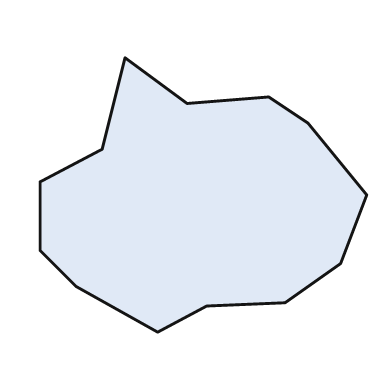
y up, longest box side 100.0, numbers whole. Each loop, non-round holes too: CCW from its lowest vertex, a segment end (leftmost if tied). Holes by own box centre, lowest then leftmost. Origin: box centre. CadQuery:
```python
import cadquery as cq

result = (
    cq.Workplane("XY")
    .moveTo(-14.0, -42.0)
    .lineTo(1.0, -34.0)
    .lineTo(25.0, -33.0)
    .lineTo(42.0, -21.0)
    .lineTo(50.0, 0.0)
    .lineTo(32.0, 22.0)
    .lineTo(20.0, 30.0)
    .lineTo(-5.0, 28.0)
    .lineTo(-24.0, 42.0)
    .lineTo(-31.0, 14.0)
    .lineTo(-50.0, 4.0)
    .lineTo(-50.0, -17.0)
    .lineTo(-39.0, -28.0)
    .close()
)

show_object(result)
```